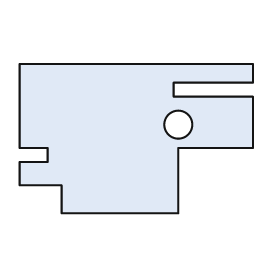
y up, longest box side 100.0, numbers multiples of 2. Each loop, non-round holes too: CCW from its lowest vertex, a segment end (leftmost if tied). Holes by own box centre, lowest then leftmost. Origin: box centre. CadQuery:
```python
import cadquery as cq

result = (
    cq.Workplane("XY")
    .moveTo(-32.0, -32.0)
    .lineTo(18.0, -32.0)
    .lineTo(18.0, -4.0)
    .lineTo(50.0, -4.0)
    .lineTo(50.0, 18.0)
    .lineTo(16.0, 18.0)
    .lineTo(16.0, 24.0)
    .lineTo(50.0, 24.0)
    .lineTo(50.0, 32.0)
    .lineTo(-50.0, 32.0)
    .lineTo(-50.0, -4.0)
    .lineTo(-38.0, -4.0)
    .lineTo(-38.0, -10.0)
    .lineTo(-50.0, -10.0)
    .lineTo(-50.0, -20.0)
    .lineTo(-32.0, -20.0)
    .close()
    .moveTo(18.0, 6.0)
    .circle(6.0)
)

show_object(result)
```